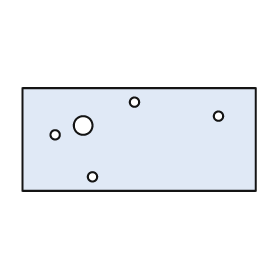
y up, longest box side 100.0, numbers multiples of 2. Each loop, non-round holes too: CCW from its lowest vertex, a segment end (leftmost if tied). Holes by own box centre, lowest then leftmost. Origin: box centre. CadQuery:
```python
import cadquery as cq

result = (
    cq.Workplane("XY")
    .moveTo(-50.0, -22.0)
    .lineTo(50.0, -22.0)
    .lineTo(50.0, 22.0)
    .lineTo(-50.0, 22.0)
    .close()
    .moveTo(-20.0, -16.0)
    .circle(2.0)
    .moveTo(-36.0, 2.0)
    .circle(2.0)
    .moveTo(-24.0, 6.0)
    .circle(4.0)
    .moveTo(34.0, 10.0)
    .circle(2.0)
    .moveTo(-2.0, 16.0)
    .circle(2.0)
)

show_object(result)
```